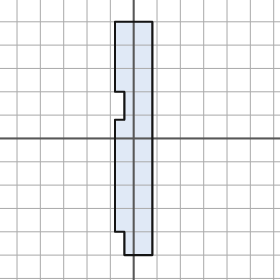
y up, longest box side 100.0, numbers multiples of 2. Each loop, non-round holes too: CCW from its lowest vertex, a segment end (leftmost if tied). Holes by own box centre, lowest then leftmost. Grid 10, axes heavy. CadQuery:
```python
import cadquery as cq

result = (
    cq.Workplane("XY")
    .moveTo(-4.0, -50.0)
    .lineTo(8.0, -50.0)
    .lineTo(8.0, 50.0)
    .lineTo(-8.0, 50.0)
    .lineTo(-8.0, 20.0)
    .lineTo(-4.0, 20.0)
    .lineTo(-4.0, 8.0)
    .lineTo(-8.0, 8.0)
    .lineTo(-8.0, -40.0)
    .lineTo(-4.0, -40.0)
    .close()
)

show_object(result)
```